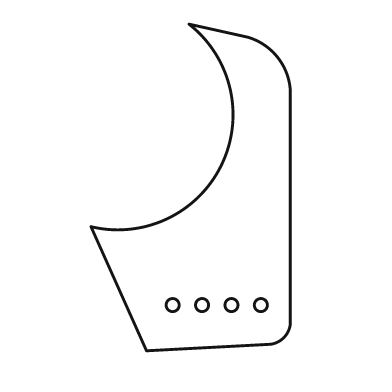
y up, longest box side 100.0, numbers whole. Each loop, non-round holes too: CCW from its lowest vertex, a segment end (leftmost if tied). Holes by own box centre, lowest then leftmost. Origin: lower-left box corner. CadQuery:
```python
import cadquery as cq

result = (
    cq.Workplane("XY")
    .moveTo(17.0, 0.0)
    .lineTo(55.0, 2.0)
    .threePointArc((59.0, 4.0), (61.0, 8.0))
    .lineTo(61.0, 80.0)
    .threePointArc((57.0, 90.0), (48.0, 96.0))
    .lineTo(30.0, 100.0)
    .threePointArc((40.0, 57.0), (0.0, 38.0))
    .close()
    .moveTo(25.0, 14.0)
    .circle(2.0)
    .moveTo(34.0, 14.0)
    .circle(2.0)
    .moveTo(43.0, 14.0)
    .circle(2.0)
    .moveTo(52.0, 14.0)
    .circle(2.0)
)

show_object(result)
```